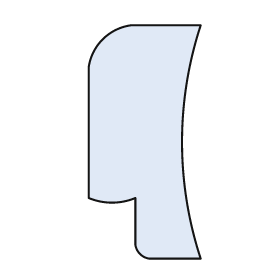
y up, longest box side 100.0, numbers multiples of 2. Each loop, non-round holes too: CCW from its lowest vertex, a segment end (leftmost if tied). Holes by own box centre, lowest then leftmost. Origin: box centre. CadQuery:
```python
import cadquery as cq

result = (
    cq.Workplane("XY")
    .moveTo(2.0, -50.0)
    .lineTo(24.0, -50.0)
    .threePointArc((16.0, 0.0), (24.0, 50.0))
    .lineTo(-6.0, 50.0)
    .threePointArc((-18.0, 44.0), (-24.0, 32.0))
    .lineTo(-24.0, -24.0)
    .threePointArc((-14.0, -26.0), (-4.0, -24.0))
    .lineTo(-4.0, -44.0)
    .threePointArc((-2.0, -48.0), (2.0, -50.0))
    .close()
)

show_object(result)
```